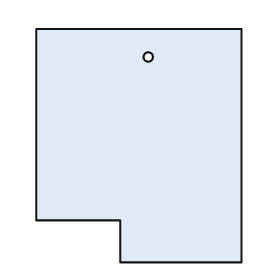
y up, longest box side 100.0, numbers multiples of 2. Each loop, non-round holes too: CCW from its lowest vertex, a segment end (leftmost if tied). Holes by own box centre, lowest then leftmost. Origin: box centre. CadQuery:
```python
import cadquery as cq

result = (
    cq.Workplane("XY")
    .moveTo(-8.0, -50.0)
    .lineTo(44.0, -50.0)
    .lineTo(44.0, 50.0)
    .lineTo(-44.0, 50.0)
    .lineTo(-44.0, -32.0)
    .lineTo(-8.0, -32.0)
    .close()
    .moveTo(4.0, 38.0)
    .circle(2.0)
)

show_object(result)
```